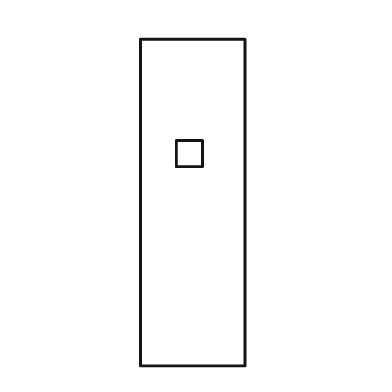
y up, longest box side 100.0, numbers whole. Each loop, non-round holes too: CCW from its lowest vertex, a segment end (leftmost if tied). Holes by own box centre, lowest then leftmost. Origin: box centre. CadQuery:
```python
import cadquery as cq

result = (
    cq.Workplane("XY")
    .moveTo(-16.0, -50.0)
    .lineTo(16.0, -50.0)
    .lineTo(16.0, 50.0)
    .lineTo(-16.0, 50.0)
    .close()
    .moveTo(-5.0, 11.0)
    .lineTo(3.0, 11.0)
    .lineTo(3.0, 19.0)
    .lineTo(-5.0, 19.0)
    .close()
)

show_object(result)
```